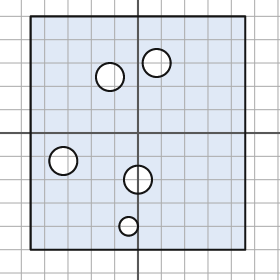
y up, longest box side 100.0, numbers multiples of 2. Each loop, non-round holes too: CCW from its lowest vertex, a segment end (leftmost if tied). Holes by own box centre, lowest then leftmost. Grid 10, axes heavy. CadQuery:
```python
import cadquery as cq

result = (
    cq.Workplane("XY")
    .moveTo(-46.0, -50.0)
    .lineTo(46.0, -50.0)
    .lineTo(46.0, 50.0)
    .lineTo(-46.0, 50.0)
    .close()
    .moveTo(-4.0, -40.0)
    .circle(4.0)
    .moveTo(0.0, -20.0)
    .circle(6.0)
    .moveTo(-32.0, -12.0)
    .circle(6.0)
    .moveTo(-12.0, 24.0)
    .circle(6.0)
    .moveTo(8.0, 30.0)
    .circle(6.0)
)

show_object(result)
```